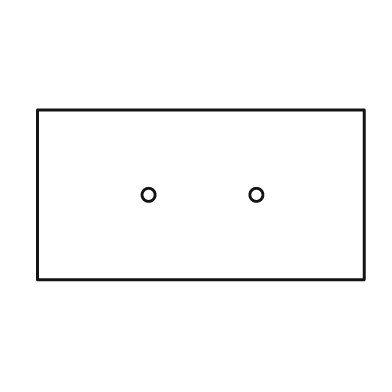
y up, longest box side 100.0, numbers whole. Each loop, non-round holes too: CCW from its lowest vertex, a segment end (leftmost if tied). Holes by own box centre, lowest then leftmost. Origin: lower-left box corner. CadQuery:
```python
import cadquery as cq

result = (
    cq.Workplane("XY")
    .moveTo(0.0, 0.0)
    .lineTo(100.0, 0.0)
    .lineTo(100.0, 52.0)
    .lineTo(0.0, 52.0)
    .close()
    .moveTo(34.0, 26.0)
    .circle(2.0)
    .moveTo(67.0, 26.0)
    .circle(2.0)
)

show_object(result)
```